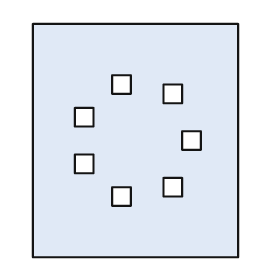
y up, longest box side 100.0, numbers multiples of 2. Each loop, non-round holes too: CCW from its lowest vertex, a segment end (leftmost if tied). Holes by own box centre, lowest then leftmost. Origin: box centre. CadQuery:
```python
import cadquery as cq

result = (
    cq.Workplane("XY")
    .moveTo(-44.0, -50.0)
    .lineTo(44.0, -50.0)
    .lineTo(44.0, 50.0)
    .lineTo(-44.0, 50.0)
    .close()
    .moveTo(-10.0, -28.0)
    .lineTo(-2.0, -28.0)
    .lineTo(-2.0, -20.0)
    .lineTo(-10.0, -20.0)
    .close()
    .moveTo(12.0, -24.0)
    .lineTo(20.0, -24.0)
    .lineTo(20.0, -16.0)
    .lineTo(12.0, -16.0)
    .close()
    .moveTo(-26.0, -14.0)
    .lineTo(-18.0, -14.0)
    .lineTo(-18.0, -6.0)
    .lineTo(-26.0, -6.0)
    .close()
    .moveTo(20.0, -4.0)
    .lineTo(28.0, -4.0)
    .lineTo(28.0, 4.0)
    .lineTo(20.0, 4.0)
    .close()
    .moveTo(-26.0, 6.0)
    .lineTo(-18.0, 6.0)
    .lineTo(-18.0, 14.0)
    .lineTo(-26.0, 14.0)
    .close()
    .moveTo(12.0, 16.0)
    .lineTo(20.0, 16.0)
    .lineTo(20.0, 24.0)
    .lineTo(12.0, 24.0)
    .close()
    .moveTo(-10.0, 20.0)
    .lineTo(-2.0, 20.0)
    .lineTo(-2.0, 28.0)
    .lineTo(-10.0, 28.0)
    .close()
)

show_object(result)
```